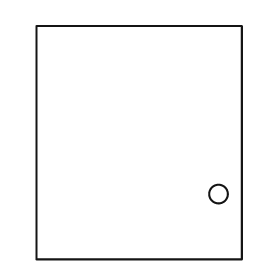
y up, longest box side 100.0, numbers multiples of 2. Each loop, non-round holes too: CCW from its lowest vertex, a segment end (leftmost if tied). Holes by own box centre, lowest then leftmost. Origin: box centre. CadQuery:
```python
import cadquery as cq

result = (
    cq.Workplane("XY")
    .moveTo(-44.0, -50.0)
    .lineTo(44.0, -50.0)
    .lineTo(44.0, 50.0)
    .lineTo(-44.0, 50.0)
    .close()
    .moveTo(34.0, -22.0)
    .circle(4.0)
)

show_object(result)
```